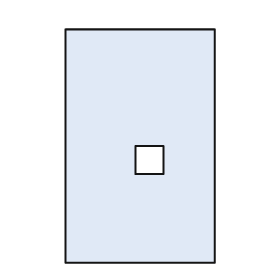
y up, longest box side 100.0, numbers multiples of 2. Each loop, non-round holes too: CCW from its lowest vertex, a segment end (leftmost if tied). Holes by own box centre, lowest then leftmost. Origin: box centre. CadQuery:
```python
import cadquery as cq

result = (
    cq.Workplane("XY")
    .moveTo(-32.0, -50.0)
    .lineTo(32.0, -50.0)
    .lineTo(32.0, 50.0)
    .lineTo(-32.0, 50.0)
    .close()
    .moveTo(-2.0, -12.0)
    .lineTo(10.0, -12.0)
    .lineTo(10.0, 0.0)
    .lineTo(-2.0, 0.0)
    .close()
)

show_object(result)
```